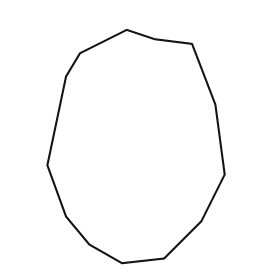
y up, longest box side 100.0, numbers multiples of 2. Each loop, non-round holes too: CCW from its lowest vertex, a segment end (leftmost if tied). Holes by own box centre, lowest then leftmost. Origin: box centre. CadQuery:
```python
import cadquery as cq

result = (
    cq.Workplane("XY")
    .moveTo(-6.0, -50.0)
    .lineTo(12.0, -48.0)
    .lineTo(28.0, -32.0)
    .lineTo(38.0, -12.0)
    .lineTo(34.0, 18.0)
    .lineTo(24.0, 44.0)
    .lineTo(8.0, 46.0)
    .lineTo(-4.0, 50.0)
    .lineTo(-24.0, 40.0)
    .lineTo(-30.0, 30.0)
    .lineTo(-38.0, -8.0)
    .lineTo(-30.0, -30.0)
    .lineTo(-20.0, -42.0)
    .close()
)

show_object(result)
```